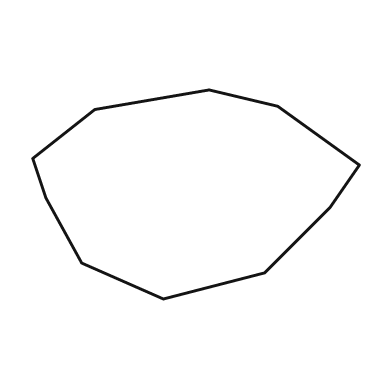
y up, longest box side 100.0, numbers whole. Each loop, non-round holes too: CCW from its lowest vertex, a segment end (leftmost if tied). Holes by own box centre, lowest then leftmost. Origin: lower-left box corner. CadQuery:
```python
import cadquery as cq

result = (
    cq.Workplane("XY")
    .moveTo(40.0, 0.0)
    .lineTo(71.0, 8.0)
    .lineTo(91.0, 28.0)
    .lineTo(100.0, 41.0)
    .lineTo(75.0, 59.0)
    .lineTo(54.0, 64.0)
    .lineTo(19.0, 58.0)
    .lineTo(0.0, 43.0)
    .lineTo(4.0, 31.0)
    .lineTo(15.0, 11.0)
    .close()
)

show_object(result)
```